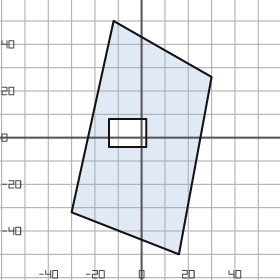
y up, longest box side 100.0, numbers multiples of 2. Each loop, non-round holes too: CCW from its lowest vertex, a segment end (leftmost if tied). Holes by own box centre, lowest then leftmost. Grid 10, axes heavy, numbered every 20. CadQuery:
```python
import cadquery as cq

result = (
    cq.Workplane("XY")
    .moveTo(16.0, -50.0)
    .lineTo(30.0, 26.0)
    .lineTo(-12.0, 50.0)
    .lineTo(-30.0, -32.0)
    .close()
    .moveTo(-14.0, -4.0)
    .lineTo(2.0, -4.0)
    .lineTo(2.0, 8.0)
    .lineTo(-14.0, 8.0)
    .close()
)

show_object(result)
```